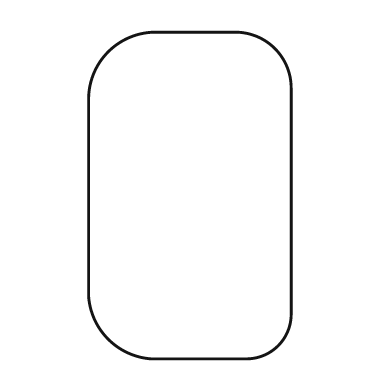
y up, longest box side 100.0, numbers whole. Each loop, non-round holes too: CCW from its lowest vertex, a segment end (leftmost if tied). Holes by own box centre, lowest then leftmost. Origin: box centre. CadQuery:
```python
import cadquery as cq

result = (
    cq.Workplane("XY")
    .moveTo(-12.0, -50.0)
    .lineTo(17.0, -50.0)
    .threePointArc((27.0, -46.0), (31.0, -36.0))
    .lineTo(31.0, 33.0)
    .threePointArc((26.0, 45.0), (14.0, 50.0))
    .lineTo(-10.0, 50.0)
    .threePointArc((-25.0, 44.0), (-31.0, 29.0))
    .lineTo(-31.0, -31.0)
    .threePointArc((-25.0, -44.0), (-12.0, -50.0))
    .close()
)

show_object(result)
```